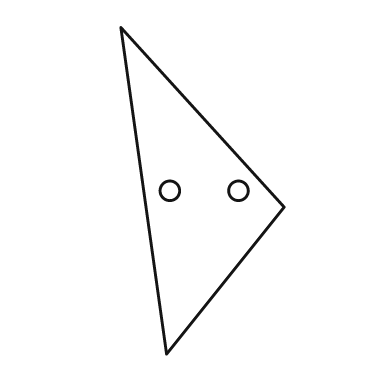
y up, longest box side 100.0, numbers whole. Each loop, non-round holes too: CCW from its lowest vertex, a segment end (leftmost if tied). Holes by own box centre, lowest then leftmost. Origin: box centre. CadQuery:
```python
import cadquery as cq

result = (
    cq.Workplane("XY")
    .moveTo(-11.0, -50.0)
    .lineTo(25.0, -5.0)
    .lineTo(-25.0, 50.0)
    .close()
    .moveTo(-10.0, 0.0)
    .circle(3.0)
    .moveTo(11.0, 0.0)
    .circle(3.0)
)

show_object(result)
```